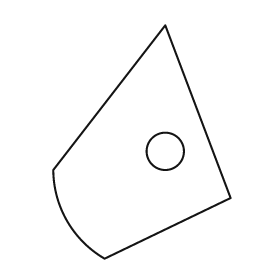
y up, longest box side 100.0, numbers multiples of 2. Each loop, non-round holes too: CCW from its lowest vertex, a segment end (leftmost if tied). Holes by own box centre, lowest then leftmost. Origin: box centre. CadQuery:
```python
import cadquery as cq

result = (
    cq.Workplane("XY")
    .moveTo(-16.0, -50.0)
    .lineTo(38.0, -24.0)
    .lineTo(10.0, 50.0)
    .lineTo(-38.0, -12.0)
    .threePointArc((-32.0, -34.0), (-16.0, -50.0))
    .close()
    .moveTo(10.0, -4.0)
    .circle(8.0)
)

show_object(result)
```